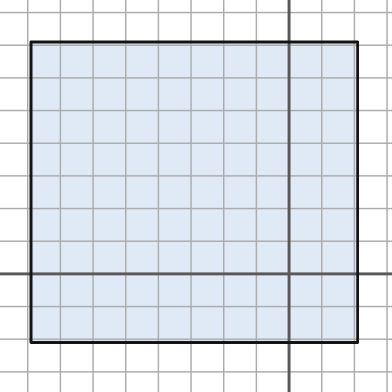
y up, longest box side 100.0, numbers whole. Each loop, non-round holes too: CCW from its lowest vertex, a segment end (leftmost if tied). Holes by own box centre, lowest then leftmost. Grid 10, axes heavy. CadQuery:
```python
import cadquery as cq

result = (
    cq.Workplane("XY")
    .moveTo(-79.0, -21.0)
    .lineTo(21.0, -21.0)
    .lineTo(21.0, 71.0)
    .lineTo(-79.0, 71.0)
    .close()
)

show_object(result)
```